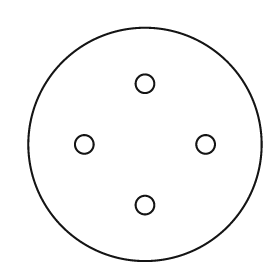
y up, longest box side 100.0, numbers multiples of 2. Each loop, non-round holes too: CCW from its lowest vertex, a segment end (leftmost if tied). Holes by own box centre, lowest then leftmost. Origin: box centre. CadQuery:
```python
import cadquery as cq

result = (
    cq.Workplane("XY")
    .moveTo(0.0, 0.0)
    .circle(50.0)
    .moveTo(0.0, -26.0)
    .circle(4.0)
    .moveTo(-26.0, 0.0)
    .circle(4.0)
    .moveTo(26.0, 0.0)
    .circle(4.0)
    .moveTo(0.0, 26.0)
    .circle(4.0)
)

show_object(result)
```